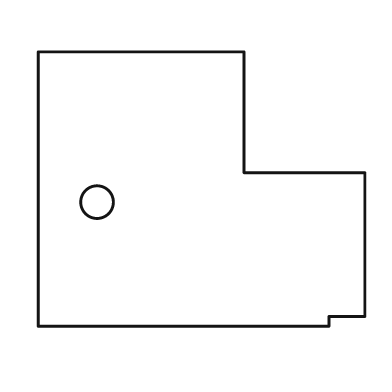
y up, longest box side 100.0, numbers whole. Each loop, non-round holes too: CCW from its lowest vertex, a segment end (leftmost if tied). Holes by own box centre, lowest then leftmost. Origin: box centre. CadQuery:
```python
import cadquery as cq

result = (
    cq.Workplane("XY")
    .moveTo(-50.0, -42.0)
    .lineTo(39.0, -42.0)
    .lineTo(39.0, -39.0)
    .lineTo(50.0, -39.0)
    .lineTo(50.0, 5.0)
    .lineTo(13.0, 5.0)
    .lineTo(13.0, 42.0)
    .lineTo(-50.0, 42.0)
    .close()
    .moveTo(-32.0, -4.0)
    .circle(5.0)
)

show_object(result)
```